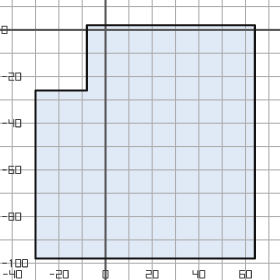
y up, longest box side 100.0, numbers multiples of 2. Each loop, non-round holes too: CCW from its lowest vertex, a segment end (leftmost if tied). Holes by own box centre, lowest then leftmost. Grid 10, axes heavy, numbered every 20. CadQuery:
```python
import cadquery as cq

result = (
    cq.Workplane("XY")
    .moveTo(-30.0, -98.0)
    .lineTo(64.0, -98.0)
    .lineTo(64.0, 2.0)
    .lineTo(-8.0, 2.0)
    .lineTo(-8.0, -26.0)
    .lineTo(-30.0, -26.0)
    .close()
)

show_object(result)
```